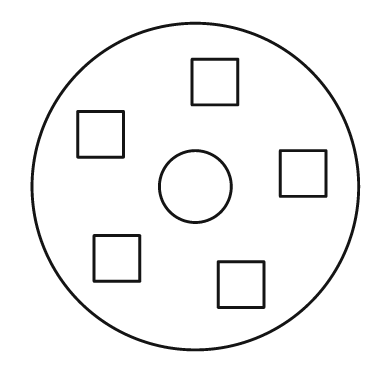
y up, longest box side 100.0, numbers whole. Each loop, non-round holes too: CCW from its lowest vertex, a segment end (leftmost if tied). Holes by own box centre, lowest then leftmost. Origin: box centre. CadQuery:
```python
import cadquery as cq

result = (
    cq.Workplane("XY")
    .moveTo(0.0, 0.0)
    .circle(50.0)
    .moveTo(7.0, -37.0)
    .lineTo(21.0, -37.0)
    .lineTo(21.0, -23.0)
    .lineTo(7.0, -23.0)
    .close()
    .moveTo(-31.0, -29.0)
    .lineTo(-17.0, -29.0)
    .lineTo(-17.0, -15.0)
    .lineTo(-31.0, -15.0)
    .close()
    .moveTo(0.0, 0.0)
    .circle(11.0)
    .moveTo(26.0, -3.0)
    .lineTo(40.0, -3.0)
    .lineTo(40.0, 11.0)
    .lineTo(26.0, 11.0)
    .close()
    .moveTo(-36.0, 9.0)
    .lineTo(-22.0, 9.0)
    .lineTo(-22.0, 23.0)
    .lineTo(-36.0, 23.0)
    .close()
    .moveTo(-1.0, 25.0)
    .lineTo(13.0, 25.0)
    .lineTo(13.0, 39.0)
    .lineTo(-1.0, 39.0)
    .close()
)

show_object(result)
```